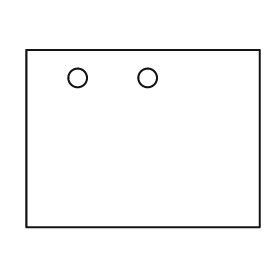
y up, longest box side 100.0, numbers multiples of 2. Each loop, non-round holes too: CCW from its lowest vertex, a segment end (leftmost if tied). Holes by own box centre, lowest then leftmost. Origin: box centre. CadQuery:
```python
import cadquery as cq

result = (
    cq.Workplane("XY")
    .moveTo(-50.0, -38.0)
    .lineTo(50.0, -38.0)
    .lineTo(50.0, 38.0)
    .lineTo(-50.0, 38.0)
    .close()
    .moveTo(-28.0, 26.0)
    .circle(4.0)
    .moveTo(2.0, 26.0)
    .circle(4.0)
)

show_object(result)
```